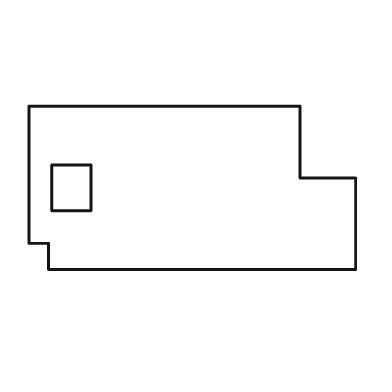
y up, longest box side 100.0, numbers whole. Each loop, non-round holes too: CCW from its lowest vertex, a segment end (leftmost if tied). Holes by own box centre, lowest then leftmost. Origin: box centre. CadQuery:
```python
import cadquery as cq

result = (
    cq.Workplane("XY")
    .moveTo(-44.0, -25.0)
    .lineTo(50.0, -25.0)
    .lineTo(50.0, 3.0)
    .lineTo(33.0, 3.0)
    .lineTo(33.0, 25.0)
    .lineTo(-50.0, 25.0)
    .lineTo(-50.0, -17.0)
    .lineTo(-44.0, -17.0)
    .close()
    .moveTo(-43.0, -7.0)
    .lineTo(-31.0, -7.0)
    .lineTo(-31.0, 7.0)
    .lineTo(-43.0, 7.0)
    .close()
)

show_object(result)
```